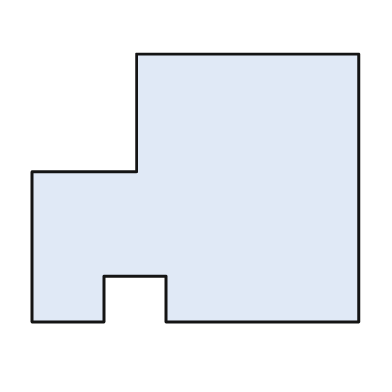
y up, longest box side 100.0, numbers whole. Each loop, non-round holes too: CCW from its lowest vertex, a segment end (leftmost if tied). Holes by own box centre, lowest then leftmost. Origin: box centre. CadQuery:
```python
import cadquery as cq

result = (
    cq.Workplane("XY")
    .moveTo(-50.0, -41.0)
    .lineTo(-28.0, -41.0)
    .lineTo(-28.0, -27.0)
    .lineTo(-9.0, -27.0)
    .lineTo(-9.0, -41.0)
    .lineTo(50.0, -41.0)
    .lineTo(50.0, 41.0)
    .lineTo(-18.0, 41.0)
    .lineTo(-18.0, 5.0)
    .lineTo(-50.0, 5.0)
    .close()
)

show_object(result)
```